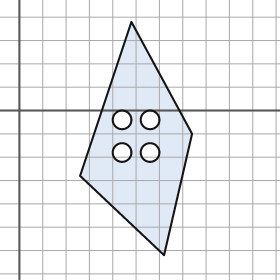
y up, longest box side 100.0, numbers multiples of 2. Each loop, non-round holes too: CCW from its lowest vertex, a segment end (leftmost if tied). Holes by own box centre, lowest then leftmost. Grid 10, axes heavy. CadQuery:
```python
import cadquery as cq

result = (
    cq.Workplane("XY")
    .moveTo(62.0, -62.0)
    .lineTo(74.0, -10.0)
    .lineTo(48.0, 38.0)
    .lineTo(26.0, -28.0)
    .close()
    .moveTo(44.0, -18.0)
    .circle(4.0)
    .moveTo(56.0, -18.0)
    .circle(4.0)
    .moveTo(44.0, -4.0)
    .circle(4.0)
    .moveTo(56.0, -4.0)
    .circle(4.0)
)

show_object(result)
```